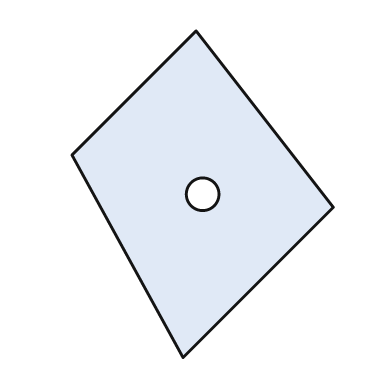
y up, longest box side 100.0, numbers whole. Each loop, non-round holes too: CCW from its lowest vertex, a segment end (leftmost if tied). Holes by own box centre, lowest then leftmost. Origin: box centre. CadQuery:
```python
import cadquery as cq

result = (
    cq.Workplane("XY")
    .moveTo(-6.0, -50.0)
    .lineTo(40.0, -4.0)
    .lineTo(-2.0, 50.0)
    .lineTo(-40.0, 12.0)
    .close()
    .moveTo(0.0, 0.0)
    .circle(5.0)
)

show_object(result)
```